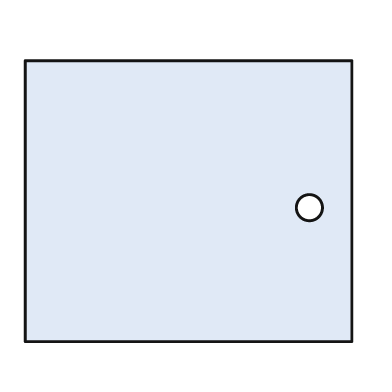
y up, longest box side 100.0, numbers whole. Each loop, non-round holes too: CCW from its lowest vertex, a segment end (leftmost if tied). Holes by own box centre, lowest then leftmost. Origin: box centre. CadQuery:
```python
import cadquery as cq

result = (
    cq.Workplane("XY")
    .moveTo(-50.0, -43.0)
    .lineTo(50.0, -43.0)
    .lineTo(50.0, 43.0)
    .lineTo(-50.0, 43.0)
    .close()
    .moveTo(37.0, -2.0)
    .circle(4.0)
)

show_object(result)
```